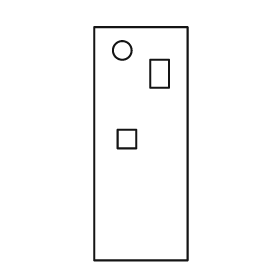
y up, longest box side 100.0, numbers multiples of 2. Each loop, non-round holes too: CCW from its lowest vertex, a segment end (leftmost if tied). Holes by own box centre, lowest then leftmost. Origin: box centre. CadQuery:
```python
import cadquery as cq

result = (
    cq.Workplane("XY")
    .moveTo(-20.0, -50.0)
    .lineTo(20.0, -50.0)
    .lineTo(20.0, 50.0)
    .lineTo(-20.0, 50.0)
    .close()
    .moveTo(-10.0, -2.0)
    .lineTo(-2.0, -2.0)
    .lineTo(-2.0, 6.0)
    .lineTo(-10.0, 6.0)
    .close()
    .moveTo(4.0, 24.0)
    .lineTo(12.0, 24.0)
    .lineTo(12.0, 36.0)
    .lineTo(4.0, 36.0)
    .close()
    .moveTo(-8.0, 40.0)
    .circle(4.0)
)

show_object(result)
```